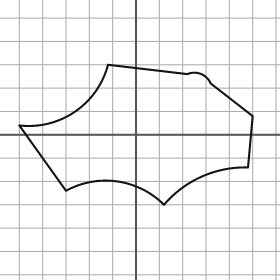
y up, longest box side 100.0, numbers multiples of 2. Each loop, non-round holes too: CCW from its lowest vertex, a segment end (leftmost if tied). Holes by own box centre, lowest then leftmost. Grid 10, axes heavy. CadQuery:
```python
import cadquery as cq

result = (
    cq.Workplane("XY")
    .moveTo(12.0, -30.0)
    .threePointArc((28.0, -18.0), (48.0, -14.0))
    .lineTo(50.0, 8.0)
    .lineTo(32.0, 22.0)
    .threePointArc((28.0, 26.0), (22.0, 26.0))
    .lineTo(-12.0, 30.0)
    .threePointArc((-26.0, 10.0), (-50.0, 4.0))
    .lineTo(-30.0, -24.0)
    .threePointArc((-8.0, -20.0), (12.0, -30.0))
    .close()
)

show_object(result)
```